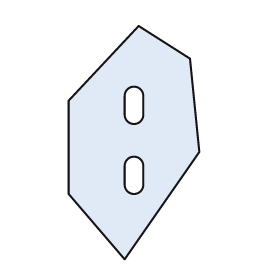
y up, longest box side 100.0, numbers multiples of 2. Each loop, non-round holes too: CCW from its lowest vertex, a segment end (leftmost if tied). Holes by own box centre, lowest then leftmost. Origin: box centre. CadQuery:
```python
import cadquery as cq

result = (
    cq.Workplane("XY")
    .moveTo(-4.0, -50.0)
    .lineTo(28.0, -4.0)
    .lineTo(24.0, 36.0)
    .lineTo(2.0, 50.0)
    .lineTo(-28.0, 18.0)
    .lineTo(-28.0, -22.0)
    .close()
    .moveTo(-4.0, -18.0)
    .threePointArc((0.0, -22.0), (4.0, -18.0))
    .lineTo(4.0, -10.0)
    .threePointArc((0.0, -6.0), (-4.0, -10.0))
    .close()
    .moveTo(-4.0, 12.0)
    .threePointArc((0.0, 8.0), (4.0, 12.0))
    .lineTo(4.0, 20.0)
    .threePointArc((0.0, 24.0), (-4.0, 20.0))
    .close()
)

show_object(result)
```